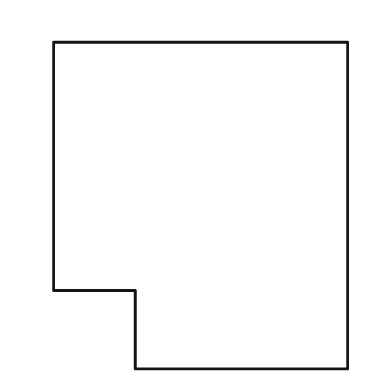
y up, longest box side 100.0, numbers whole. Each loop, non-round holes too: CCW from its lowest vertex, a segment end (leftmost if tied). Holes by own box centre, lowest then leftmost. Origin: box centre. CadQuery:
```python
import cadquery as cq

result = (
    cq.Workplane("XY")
    .moveTo(-20.0, -50.0)
    .lineTo(45.0, -50.0)
    .lineTo(45.0, 50.0)
    .lineTo(-45.0, 50.0)
    .lineTo(-45.0, -26.0)
    .lineTo(-20.0, -26.0)
    .close()
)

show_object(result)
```